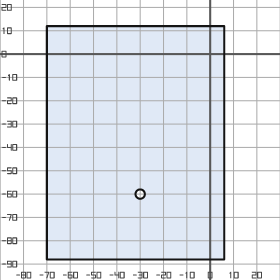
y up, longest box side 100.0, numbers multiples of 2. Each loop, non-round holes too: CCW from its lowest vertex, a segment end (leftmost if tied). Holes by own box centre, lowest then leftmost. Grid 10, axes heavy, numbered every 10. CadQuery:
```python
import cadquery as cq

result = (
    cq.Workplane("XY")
    .moveTo(-70.0, -88.0)
    .lineTo(6.0, -88.0)
    .lineTo(6.0, 12.0)
    .lineTo(-70.0, 12.0)
    .close()
    .moveTo(-30.0, -60.0)
    .circle(2.0)
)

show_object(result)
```